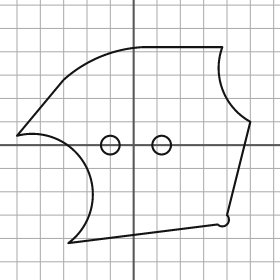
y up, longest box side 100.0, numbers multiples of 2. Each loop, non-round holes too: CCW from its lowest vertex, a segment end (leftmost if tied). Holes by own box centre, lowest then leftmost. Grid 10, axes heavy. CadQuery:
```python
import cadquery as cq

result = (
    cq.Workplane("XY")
    .moveTo(-28.0, -42.0)
    .lineTo(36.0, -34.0)
    .threePointArc((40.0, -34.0), (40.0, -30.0))
    .lineTo(50.0, 10.0)
    .threePointArc((38.0, 24.0), (38.0, 42.0))
    .lineTo(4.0, 42.0)
    .threePointArc((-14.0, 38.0), (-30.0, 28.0))
    .lineTo(-50.0, 4.0)
    .threePointArc((-20.0, -10.0), (-28.0, -42.0))
    .close()
    .moveTo(-10.0, 0.0)
    .circle(4.0)
    .moveTo(12.0, 0.0)
    .circle(4.0)
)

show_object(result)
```